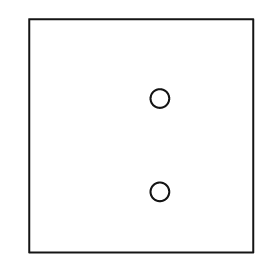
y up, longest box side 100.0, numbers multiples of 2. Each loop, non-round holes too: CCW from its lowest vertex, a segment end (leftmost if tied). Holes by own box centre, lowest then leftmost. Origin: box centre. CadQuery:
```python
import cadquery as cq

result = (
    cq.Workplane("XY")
    .moveTo(-48.0, -50.0)
    .lineTo(48.0, -50.0)
    .lineTo(48.0, 50.0)
    .lineTo(-48.0, 50.0)
    .close()
    .moveTo(8.0, -24.0)
    .circle(4.0)
    .moveTo(8.0, 16.0)
    .circle(4.0)
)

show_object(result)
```